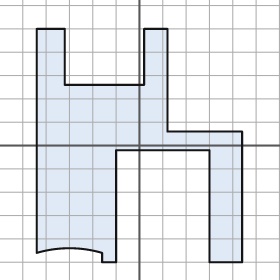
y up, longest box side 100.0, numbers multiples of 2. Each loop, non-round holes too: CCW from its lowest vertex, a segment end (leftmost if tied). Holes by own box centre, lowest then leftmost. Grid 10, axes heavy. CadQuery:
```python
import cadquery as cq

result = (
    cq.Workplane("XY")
    .moveTo(-16.0, -50.0)
    .lineTo(-10.0, -50.0)
    .lineTo(-10.0, -2.0)
    .lineTo(30.0, -2.0)
    .lineTo(30.0, -50.0)
    .lineTo(44.0, -50.0)
    .lineTo(44.0, 6.0)
    .lineTo(12.0, 6.0)
    .lineTo(12.0, 50.0)
    .lineTo(2.0, 50.0)
    .lineTo(2.0, 26.0)
    .lineTo(-32.0, 26.0)
    .lineTo(-32.0, 50.0)
    .lineTo(-44.0, 50.0)
    .lineTo(-44.0, -46.0)
    .threePointArc((-30.0, -44.0), (-16.0, -46.0))
    .close()
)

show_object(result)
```